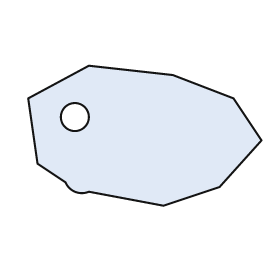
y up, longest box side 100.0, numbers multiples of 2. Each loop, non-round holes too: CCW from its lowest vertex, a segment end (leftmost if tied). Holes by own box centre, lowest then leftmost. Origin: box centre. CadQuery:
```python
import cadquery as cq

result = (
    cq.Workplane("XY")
    .moveTo(8.0, -30.0)
    .lineTo(32.0, -22.0)
    .lineTo(50.0, -2.0)
    .lineTo(38.0, 16.0)
    .lineTo(12.0, 26.0)
    .lineTo(-24.0, 30.0)
    .lineTo(-50.0, 16.0)
    .lineTo(-46.0, -12.0)
    .lineTo(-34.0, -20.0)
    .threePointArc((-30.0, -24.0), (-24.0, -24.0))
    .close()
    .moveTo(-30.0, 8.0)
    .circle(6.0)
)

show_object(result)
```